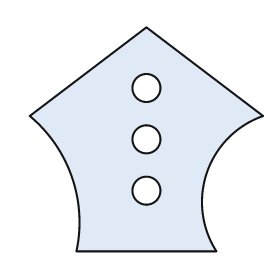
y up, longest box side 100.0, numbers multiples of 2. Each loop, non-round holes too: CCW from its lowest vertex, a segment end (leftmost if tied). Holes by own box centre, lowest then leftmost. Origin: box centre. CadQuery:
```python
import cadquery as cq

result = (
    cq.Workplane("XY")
    .moveTo(-30.0, -48.0)
    .lineTo(30.0, -48.0)
    .threePointArc((26.0, -14.0), (50.0, 10.0))
    .lineTo(0.0, 48.0)
    .lineTo(-50.0, 10.0)
    .threePointArc((-32.0, -16.0), (-30.0, -48.0))
    .close()
    .moveTo(0.0, -22.0)
    .circle(6.0)
    .moveTo(0.0, 0.0)
    .circle(6.0)
    .moveTo(0.0, 22.0)
    .circle(6.0)
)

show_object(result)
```